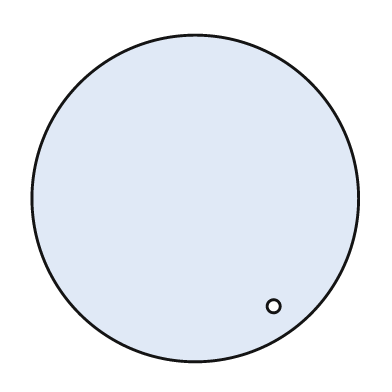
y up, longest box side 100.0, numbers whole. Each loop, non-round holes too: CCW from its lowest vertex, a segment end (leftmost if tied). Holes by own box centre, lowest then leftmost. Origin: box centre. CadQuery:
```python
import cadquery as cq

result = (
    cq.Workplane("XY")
    .moveTo(0.0, 0.0)
    .circle(50.0)
    .moveTo(24.0, -33.0)
    .circle(2.0)
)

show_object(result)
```